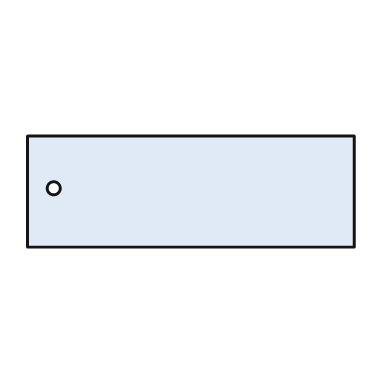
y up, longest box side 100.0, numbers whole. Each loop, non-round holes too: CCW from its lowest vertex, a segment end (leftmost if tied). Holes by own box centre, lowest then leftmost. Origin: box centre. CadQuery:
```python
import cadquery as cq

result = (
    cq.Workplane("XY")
    .moveTo(-50.0, -17.0)
    .lineTo(50.0, -17.0)
    .lineTo(50.0, 17.0)
    .lineTo(-50.0, 17.0)
    .close()
    .moveTo(-42.0, 1.0)
    .circle(2.0)
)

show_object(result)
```